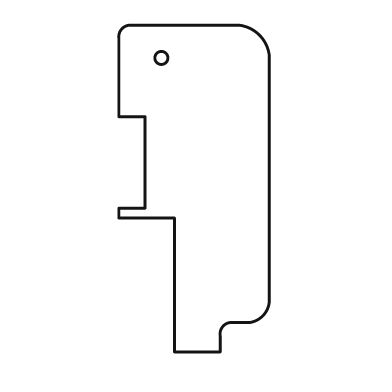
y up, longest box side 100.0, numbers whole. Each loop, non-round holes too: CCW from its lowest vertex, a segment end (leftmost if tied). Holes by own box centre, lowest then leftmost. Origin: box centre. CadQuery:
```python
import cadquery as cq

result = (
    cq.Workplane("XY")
    .moveTo(-6.0, -50.0)
    .lineTo(8.0, -50.0)
    .lineTo(8.0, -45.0)
    .threePointArc((9.0, -42.0), (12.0, -41.0))
    .lineTo(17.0, -41.0)
    .threePointArc((21.0, -39.0), (23.0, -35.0))
    .lineTo(23.0, 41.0)
    .threePointArc((20.0, 47.0), (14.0, 50.0))
    .lineTo(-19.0, 50.0)
    .threePointArc((-22.0, 49.0), (-23.0, 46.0))
    .lineTo(-23.0, 22.0)
    .lineTo(-15.0, 22.0)
    .lineTo(-15.0, -6.0)
    .lineTo(-23.0, -6.0)
    .lineTo(-23.0, -9.0)
    .lineTo(-6.0, -9.0)
    .close()
    .moveTo(-10.0, 40.0)
    .circle(2.0)
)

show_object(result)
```